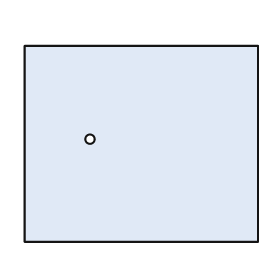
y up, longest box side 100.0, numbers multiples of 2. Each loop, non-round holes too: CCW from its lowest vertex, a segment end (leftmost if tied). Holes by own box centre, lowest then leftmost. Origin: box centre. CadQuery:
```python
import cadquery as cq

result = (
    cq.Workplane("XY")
    .moveTo(-50.0, -42.0)
    .lineTo(50.0, -42.0)
    .lineTo(50.0, 42.0)
    .lineTo(-50.0, 42.0)
    .close()
    .moveTo(-22.0, 2.0)
    .circle(2.0)
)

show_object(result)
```